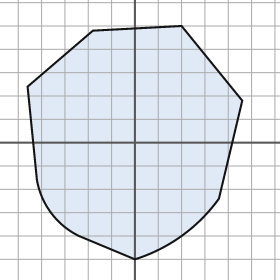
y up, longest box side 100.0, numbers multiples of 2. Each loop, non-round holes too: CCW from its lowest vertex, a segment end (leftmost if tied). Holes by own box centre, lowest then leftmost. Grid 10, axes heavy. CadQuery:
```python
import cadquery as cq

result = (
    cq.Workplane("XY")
    .moveTo(0.0, -50.0)
    .threePointArc((20.0, -40.0), (36.0, -24.0))
    .lineTo(46.0, 18.0)
    .lineTo(20.0, 50.0)
    .lineTo(-18.0, 48.0)
    .lineTo(-46.0, 24.0)
    .lineTo(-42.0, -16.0)
    .threePointArc((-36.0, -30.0), (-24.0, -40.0))
    .close()
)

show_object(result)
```